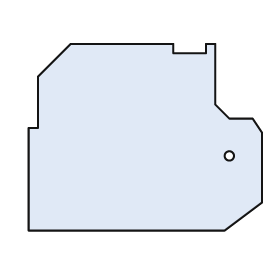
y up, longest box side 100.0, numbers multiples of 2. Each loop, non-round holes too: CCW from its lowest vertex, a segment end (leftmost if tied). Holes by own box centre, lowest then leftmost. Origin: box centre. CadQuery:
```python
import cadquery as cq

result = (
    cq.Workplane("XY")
    .moveTo(-50.0, -40.0)
    .lineTo(34.0, -40.0)
    .lineTo(50.0, -28.0)
    .lineTo(50.0, 2.0)
    .lineTo(46.0, 8.0)
    .lineTo(36.0, 8.0)
    .lineTo(30.0, 14.0)
    .lineTo(30.0, 40.0)
    .lineTo(26.0, 40.0)
    .lineTo(26.0, 36.0)
    .lineTo(12.0, 36.0)
    .lineTo(12.0, 40.0)
    .lineTo(-32.0, 40.0)
    .lineTo(-46.0, 26.0)
    .lineTo(-46.0, 4.0)
    .lineTo(-50.0, 4.0)
    .close()
    .moveTo(36.0, -8.0)
    .circle(2.0)
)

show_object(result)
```